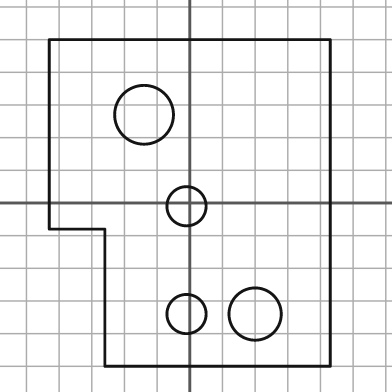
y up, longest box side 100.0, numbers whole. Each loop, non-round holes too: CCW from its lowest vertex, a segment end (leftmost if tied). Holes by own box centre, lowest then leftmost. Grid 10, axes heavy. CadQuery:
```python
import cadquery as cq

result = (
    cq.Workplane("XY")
    .moveTo(-26.0, -50.0)
    .lineTo(43.0, -50.0)
    .lineTo(43.0, 50.0)
    .lineTo(-43.0, 50.0)
    .lineTo(-43.0, -8.0)
    .lineTo(-26.0, -8.0)
    .close()
    .moveTo(-1.0, -34.0)
    .circle(6.0)
    .moveTo(20.0, -34.0)
    .circle(8.0)
    .moveTo(-1.0, -1.0)
    .circle(6.0)
    .moveTo(-14.0, 27.0)
    .circle(9.0)
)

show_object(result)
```